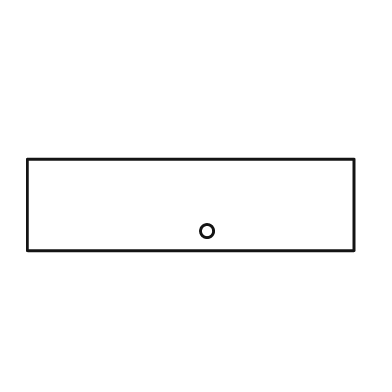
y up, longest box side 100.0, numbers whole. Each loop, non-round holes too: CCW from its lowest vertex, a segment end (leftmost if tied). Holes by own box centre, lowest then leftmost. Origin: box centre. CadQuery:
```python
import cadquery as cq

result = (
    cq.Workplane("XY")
    .moveTo(-50.0, -14.0)
    .lineTo(50.0, -14.0)
    .lineTo(50.0, 14.0)
    .lineTo(-50.0, 14.0)
    .close()
    .moveTo(5.0, -8.0)
    .circle(2.0)
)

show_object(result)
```